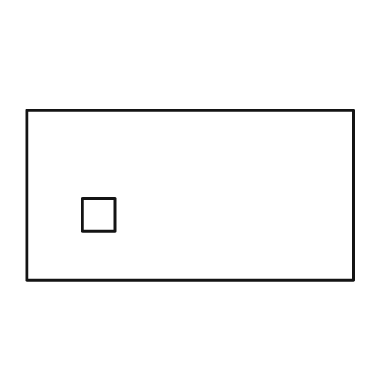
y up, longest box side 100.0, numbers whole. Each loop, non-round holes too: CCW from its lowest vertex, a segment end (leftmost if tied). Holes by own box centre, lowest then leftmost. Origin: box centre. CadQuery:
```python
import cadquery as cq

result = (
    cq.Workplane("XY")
    .moveTo(-50.0, -26.0)
    .lineTo(50.0, -26.0)
    .lineTo(50.0, 26.0)
    .lineTo(-50.0, 26.0)
    .close()
    .moveTo(-33.0, -11.0)
    .lineTo(-23.0, -11.0)
    .lineTo(-23.0, -1.0)
    .lineTo(-33.0, -1.0)
    .close()
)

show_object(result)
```